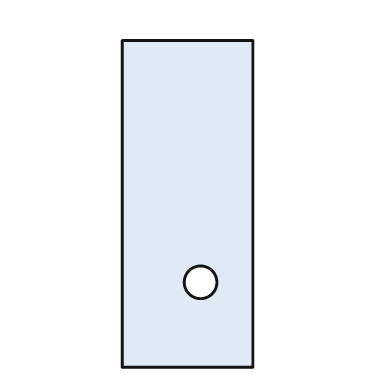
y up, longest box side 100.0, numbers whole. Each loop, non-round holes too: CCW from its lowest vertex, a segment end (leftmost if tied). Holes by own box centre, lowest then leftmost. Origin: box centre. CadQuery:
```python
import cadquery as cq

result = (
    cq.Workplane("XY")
    .moveTo(-20.0, -50.0)
    .lineTo(20.0, -50.0)
    .lineTo(20.0, 50.0)
    .lineTo(-20.0, 50.0)
    .close()
    .moveTo(4.0, -24.0)
    .circle(5.0)
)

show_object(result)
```